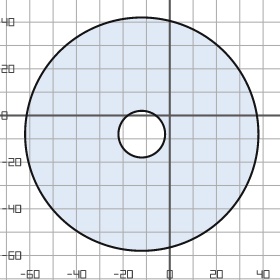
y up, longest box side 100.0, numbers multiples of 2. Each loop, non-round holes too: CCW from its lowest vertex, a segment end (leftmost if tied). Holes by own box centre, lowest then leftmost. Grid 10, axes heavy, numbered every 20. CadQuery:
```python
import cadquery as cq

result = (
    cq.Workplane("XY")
    .moveTo(-12.0, -8.0)
    .circle(50.0)
    .moveTo(-12.0, -8.0)
    .circle(10.0)
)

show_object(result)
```